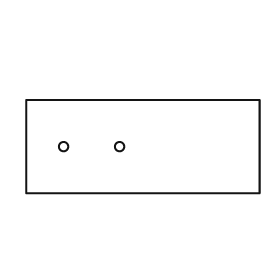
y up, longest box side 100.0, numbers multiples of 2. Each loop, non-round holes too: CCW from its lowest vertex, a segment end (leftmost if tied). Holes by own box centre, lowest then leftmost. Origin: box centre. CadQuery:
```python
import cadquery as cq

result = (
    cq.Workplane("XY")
    .moveTo(-50.0, -20.0)
    .lineTo(50.0, -20.0)
    .lineTo(50.0, 20.0)
    .lineTo(-50.0, 20.0)
    .close()
    .moveTo(-34.0, 0.0)
    .circle(2.0)
    .moveTo(-10.0, 0.0)
    .circle(2.0)
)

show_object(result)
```